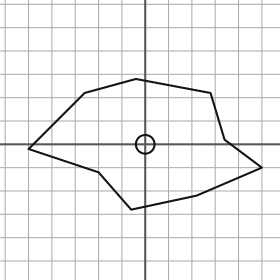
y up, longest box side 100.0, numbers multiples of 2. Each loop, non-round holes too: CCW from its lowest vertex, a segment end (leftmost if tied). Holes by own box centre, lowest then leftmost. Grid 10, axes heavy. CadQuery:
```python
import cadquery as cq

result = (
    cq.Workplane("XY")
    .moveTo(-6.0, -28.0)
    .lineTo(22.0, -22.0)
    .lineTo(50.0, -10.0)
    .lineTo(34.0, 2.0)
    .lineTo(28.0, 22.0)
    .lineTo(-4.0, 28.0)
    .lineTo(-26.0, 22.0)
    .lineTo(-50.0, -2.0)
    .lineTo(-20.0, -12.0)
    .close()
    .moveTo(0.0, 0.0)
    .circle(4.0)
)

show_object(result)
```